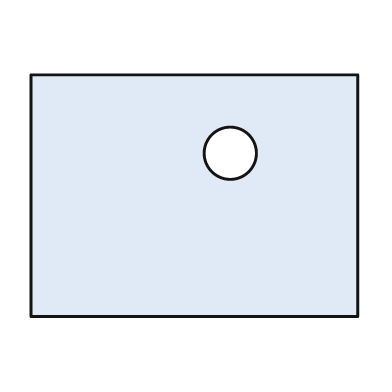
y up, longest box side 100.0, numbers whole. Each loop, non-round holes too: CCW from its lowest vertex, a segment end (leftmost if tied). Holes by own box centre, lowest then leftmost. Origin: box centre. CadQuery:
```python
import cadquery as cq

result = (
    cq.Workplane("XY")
    .moveTo(-50.0, -37.0)
    .lineTo(50.0, -37.0)
    .lineTo(50.0, 37.0)
    .lineTo(-50.0, 37.0)
    .close()
    .moveTo(11.0, 13.0)
    .circle(8.0)
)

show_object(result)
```